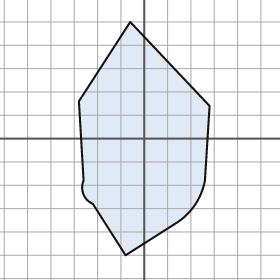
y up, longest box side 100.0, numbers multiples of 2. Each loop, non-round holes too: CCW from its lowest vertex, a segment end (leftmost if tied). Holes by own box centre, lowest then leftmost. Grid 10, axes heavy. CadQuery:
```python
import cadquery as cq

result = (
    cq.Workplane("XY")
    .moveTo(-8.0, -50.0)
    .lineTo(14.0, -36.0)
    .threePointArc((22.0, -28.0), (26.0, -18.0))
    .lineTo(28.0, 14.0)
    .lineTo(-6.0, 50.0)
    .lineTo(-28.0, 16.0)
    .lineTo(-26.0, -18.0)
    .threePointArc((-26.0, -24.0), (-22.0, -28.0))
    .close()
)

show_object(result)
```